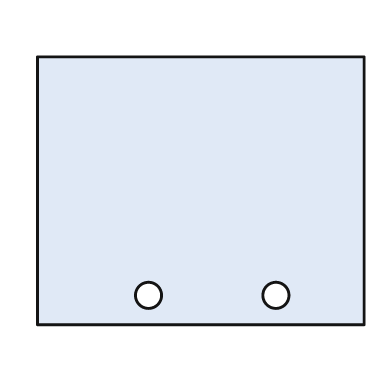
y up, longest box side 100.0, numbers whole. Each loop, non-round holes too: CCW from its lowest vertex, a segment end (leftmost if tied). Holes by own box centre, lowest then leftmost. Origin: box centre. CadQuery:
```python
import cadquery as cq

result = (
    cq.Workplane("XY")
    .moveTo(-50.0, -41.0)
    .lineTo(50.0, -41.0)
    .lineTo(50.0, 41.0)
    .lineTo(-50.0, 41.0)
    .close()
    .moveTo(-16.0, -32.0)
    .circle(4.0)
    .moveTo(23.0, -32.0)
    .circle(4.0)
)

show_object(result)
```